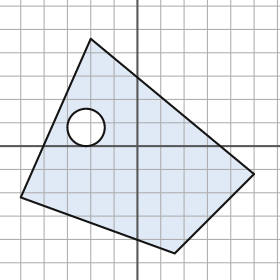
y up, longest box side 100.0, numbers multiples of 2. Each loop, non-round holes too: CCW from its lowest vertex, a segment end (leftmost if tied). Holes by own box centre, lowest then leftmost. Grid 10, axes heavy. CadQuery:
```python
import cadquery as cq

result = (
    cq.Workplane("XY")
    .moveTo(16.0, -46.0)
    .lineTo(50.0, -12.0)
    .lineTo(-20.0, 46.0)
    .lineTo(-50.0, -22.0)
    .close()
    .moveTo(-22.0, 8.0)
    .circle(8.0)
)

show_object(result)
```